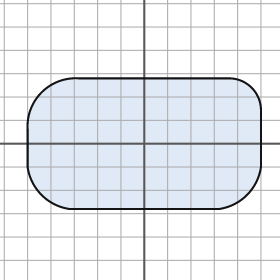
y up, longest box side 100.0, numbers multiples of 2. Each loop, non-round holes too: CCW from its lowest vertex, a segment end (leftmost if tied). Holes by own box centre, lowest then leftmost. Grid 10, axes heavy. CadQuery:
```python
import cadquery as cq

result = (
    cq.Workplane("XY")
    .moveTo(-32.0, -28.0)
    .lineTo(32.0, -28.0)
    .threePointArc((44.0, -22.0), (50.0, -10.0))
    .lineTo(50.0, 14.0)
    .threePointArc((46.0, 24.0), (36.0, 28.0))
    .lineTo(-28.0, 28.0)
    .threePointArc((-44.0, 22.0), (-50.0, 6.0))
    .lineTo(-50.0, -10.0)
    .threePointArc((-44.0, -22.0), (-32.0, -28.0))
    .close()
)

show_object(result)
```